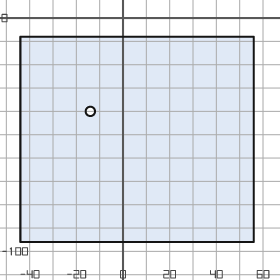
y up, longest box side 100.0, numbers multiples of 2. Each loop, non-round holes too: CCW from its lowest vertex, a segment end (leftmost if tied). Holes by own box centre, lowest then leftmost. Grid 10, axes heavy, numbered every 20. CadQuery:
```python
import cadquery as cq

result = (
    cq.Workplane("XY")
    .moveTo(-44.0, -96.0)
    .lineTo(56.0, -96.0)
    .lineTo(56.0, -8.0)
    .lineTo(-44.0, -8.0)
    .close()
    .moveTo(-14.0, -40.0)
    .circle(2.0)
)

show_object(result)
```